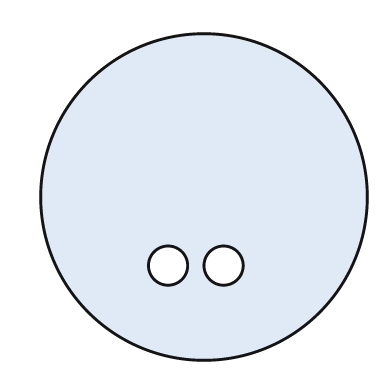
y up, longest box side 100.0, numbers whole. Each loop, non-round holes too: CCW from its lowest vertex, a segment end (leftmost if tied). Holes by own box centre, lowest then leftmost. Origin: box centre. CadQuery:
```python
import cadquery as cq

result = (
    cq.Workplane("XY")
    .moveTo(0.0, 0.0)
    .circle(50.0)
    .moveTo(-11.0, -21.0)
    .circle(6.0)
    .moveTo(6.0, -21.0)
    .circle(6.0)
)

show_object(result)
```